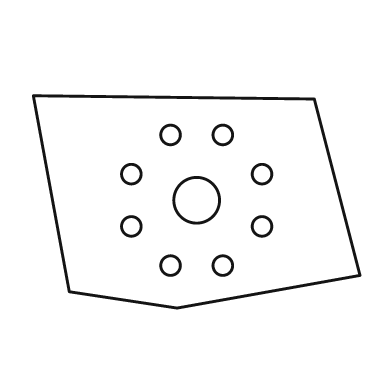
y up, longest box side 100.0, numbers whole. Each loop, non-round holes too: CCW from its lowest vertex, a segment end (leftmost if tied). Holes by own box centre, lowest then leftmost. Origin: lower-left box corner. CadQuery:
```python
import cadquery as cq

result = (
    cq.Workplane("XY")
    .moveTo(44.0, 0.0)
    .lineTo(100.0, 10.0)
    .lineTo(86.0, 64.0)
    .lineTo(0.0, 65.0)
    .lineTo(11.0, 5.0)
    .close()
    .moveTo(42.0, 13.0)
    .circle(3.0)
    .moveTo(58.0, 13.0)
    .circle(3.0)
    .moveTo(30.0, 25.0)
    .circle(3.0)
    .moveTo(70.0, 25.0)
    .circle(3.0)
    .moveTo(50.0, 33.0)
    .circle(7.0)
    .moveTo(30.0, 41.0)
    .circle(3.0)
    .moveTo(70.0, 41.0)
    .circle(3.0)
    .moveTo(42.0, 53.0)
    .circle(3.0)
    .moveTo(58.0, 53.0)
    .circle(3.0)
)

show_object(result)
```